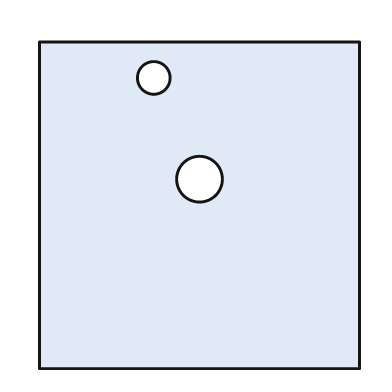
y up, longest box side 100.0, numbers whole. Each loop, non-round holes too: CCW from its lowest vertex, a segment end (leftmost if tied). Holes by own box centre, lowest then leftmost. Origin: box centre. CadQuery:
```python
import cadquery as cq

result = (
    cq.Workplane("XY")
    .moveTo(-49.0, -50.0)
    .lineTo(49.0, -50.0)
    .lineTo(49.0, 50.0)
    .lineTo(-49.0, 50.0)
    .close()
    .moveTo(0.0, 8.0)
    .circle(7.0)
    .moveTo(-14.0, 39.0)
    .circle(5.0)
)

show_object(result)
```